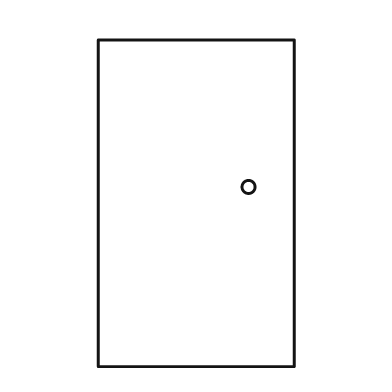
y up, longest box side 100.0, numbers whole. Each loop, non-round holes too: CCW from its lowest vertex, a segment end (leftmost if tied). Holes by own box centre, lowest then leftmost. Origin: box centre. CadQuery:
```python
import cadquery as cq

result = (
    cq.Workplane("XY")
    .moveTo(-30.0, -50.0)
    .lineTo(30.0, -50.0)
    .lineTo(30.0, 50.0)
    .lineTo(-30.0, 50.0)
    .close()
    .moveTo(16.0, 5.0)
    .circle(2.0)
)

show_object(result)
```